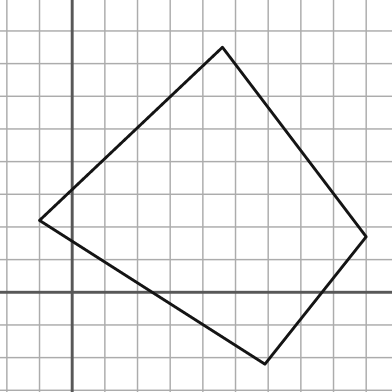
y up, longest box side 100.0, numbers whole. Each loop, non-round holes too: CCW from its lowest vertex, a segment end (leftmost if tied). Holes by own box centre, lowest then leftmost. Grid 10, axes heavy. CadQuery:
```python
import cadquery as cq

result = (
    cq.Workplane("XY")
    .moveTo(59.0, -22.0)
    .lineTo(90.0, 17.0)
    .lineTo(46.0, 75.0)
    .lineTo(-10.0, 22.0)
    .close()
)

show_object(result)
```